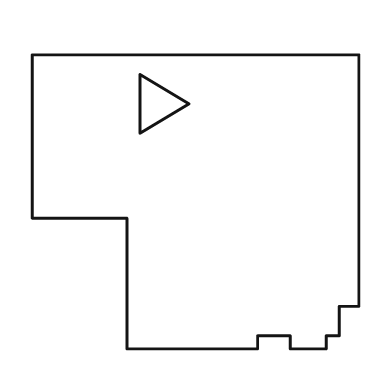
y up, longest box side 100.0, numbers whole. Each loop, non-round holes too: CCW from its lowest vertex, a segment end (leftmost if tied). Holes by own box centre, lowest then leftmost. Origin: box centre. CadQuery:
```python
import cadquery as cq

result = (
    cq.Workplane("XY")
    .moveTo(-21.0, -45.0)
    .lineTo(19.0, -45.0)
    .lineTo(19.0, -41.0)
    .lineTo(29.0, -41.0)
    .lineTo(29.0, -45.0)
    .lineTo(40.0, -45.0)
    .lineTo(40.0, -41.0)
    .lineTo(44.0, -41.0)
    .lineTo(44.0, -32.0)
    .lineTo(50.0, -32.0)
    .lineTo(50.0, 45.0)
    .lineTo(-50.0, 45.0)
    .lineTo(-50.0, -5.0)
    .lineTo(-21.0, -5.0)
    .close()
    .moveTo(-17.0, 21.0)
    .lineTo(-2.0, 30.0)
    .lineTo(-17.0, 39.0)
    .close()
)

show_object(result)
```